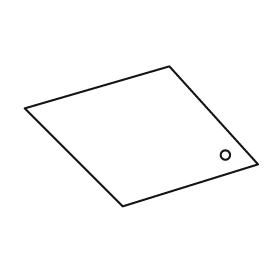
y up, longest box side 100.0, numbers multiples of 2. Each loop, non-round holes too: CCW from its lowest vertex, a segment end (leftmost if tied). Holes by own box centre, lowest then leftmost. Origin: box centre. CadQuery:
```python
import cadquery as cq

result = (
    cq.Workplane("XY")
    .moveTo(-8.0, -30.0)
    .lineTo(50.0, -12.0)
    .lineTo(12.0, 30.0)
    .lineTo(-50.0, 12.0)
    .close()
    .moveTo(36.0, -8.0)
    .circle(2.0)
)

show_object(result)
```